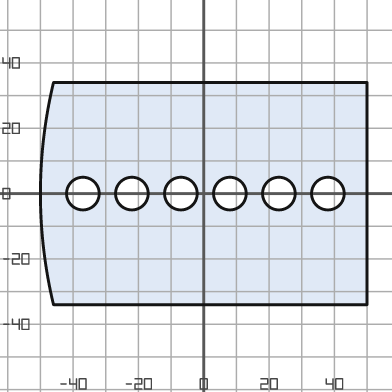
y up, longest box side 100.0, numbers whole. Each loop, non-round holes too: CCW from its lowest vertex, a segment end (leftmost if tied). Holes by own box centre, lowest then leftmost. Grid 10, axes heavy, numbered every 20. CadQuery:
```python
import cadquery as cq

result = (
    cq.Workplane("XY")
    .moveTo(-46.0, -34.0)
    .lineTo(50.0, -34.0)
    .lineTo(50.0, 34.0)
    .lineTo(-46.0, 34.0)
    .threePointArc((-50.0, 0.0), (-46.0, -34.0))
    .close()
    .moveTo(-37.0, 0.0)
    .circle(5.0)
    .moveTo(-22.0, 0.0)
    .circle(5.0)
    .moveTo(-7.0, 0.0)
    .circle(5.0)
    .moveTo(8.0, 0.0)
    .circle(5.0)
    .moveTo(23.0, 0.0)
    .circle(5.0)
    .moveTo(38.0, 0.0)
    .circle(5.0)
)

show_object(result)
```